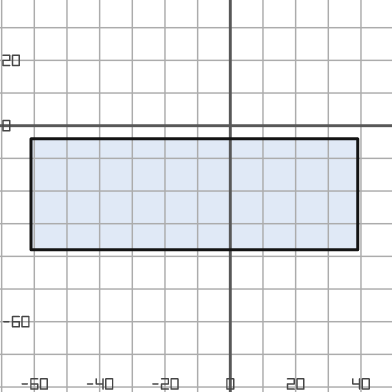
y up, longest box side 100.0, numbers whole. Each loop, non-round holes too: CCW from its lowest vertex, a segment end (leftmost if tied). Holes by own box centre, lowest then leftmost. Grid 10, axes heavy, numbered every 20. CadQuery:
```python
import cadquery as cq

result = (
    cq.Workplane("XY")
    .moveTo(-61.0, -38.0)
    .lineTo(39.0, -38.0)
    .lineTo(39.0, -4.0)
    .lineTo(-61.0, -4.0)
    .close()
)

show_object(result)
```